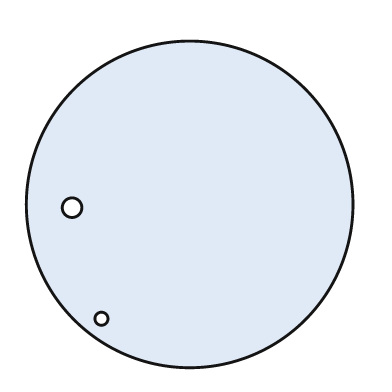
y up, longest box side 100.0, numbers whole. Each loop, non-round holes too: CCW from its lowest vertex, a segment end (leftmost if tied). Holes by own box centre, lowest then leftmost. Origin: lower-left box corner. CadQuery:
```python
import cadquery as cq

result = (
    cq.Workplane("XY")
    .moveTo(50.0, 50.0)
    .circle(50.0)
    .moveTo(23.0, 15.0)
    .circle(2.0)
    .moveTo(14.0, 49.0)
    .circle(3.0)
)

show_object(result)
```